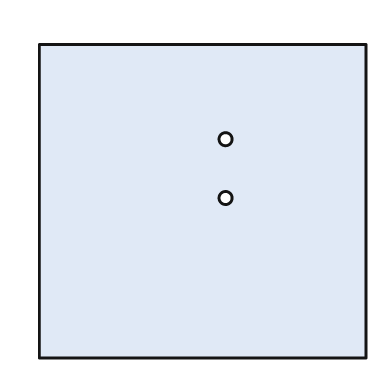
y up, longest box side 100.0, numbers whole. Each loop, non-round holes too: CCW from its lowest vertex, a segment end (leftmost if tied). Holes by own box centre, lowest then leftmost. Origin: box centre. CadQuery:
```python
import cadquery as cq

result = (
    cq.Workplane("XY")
    .moveTo(-50.0, -48.0)
    .lineTo(50.0, -48.0)
    .lineTo(50.0, 48.0)
    .lineTo(-50.0, 48.0)
    .close()
    .moveTo(7.0, 1.0)
    .circle(2.0)
    .moveTo(7.0, 19.0)
    .circle(2.0)
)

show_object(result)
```